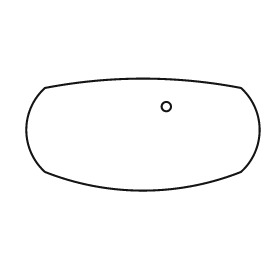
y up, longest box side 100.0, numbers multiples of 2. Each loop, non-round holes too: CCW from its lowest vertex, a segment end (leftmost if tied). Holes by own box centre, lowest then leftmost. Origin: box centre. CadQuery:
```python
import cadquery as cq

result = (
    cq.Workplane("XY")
    .moveTo(-42.0, -16.0)
    .threePointArc((0.0, -24.0), (42.0, -16.0))
    .threePointArc((50.0, 2.0), (42.0, 20.0))
    .threePointArc((0.0, 24.0), (-42.0, 20.0))
    .threePointArc((-50.0, 2.0), (-42.0, -16.0))
    .close()
    .moveTo(10.0, 12.0)
    .circle(2.0)
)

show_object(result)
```